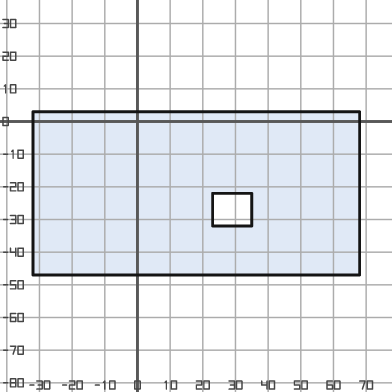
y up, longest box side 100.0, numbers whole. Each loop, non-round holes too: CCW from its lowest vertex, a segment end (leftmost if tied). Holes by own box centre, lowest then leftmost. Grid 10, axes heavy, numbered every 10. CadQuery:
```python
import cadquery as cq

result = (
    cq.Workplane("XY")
    .moveTo(-32.0, -47.0)
    .lineTo(68.0, -47.0)
    .lineTo(68.0, 3.0)
    .lineTo(-32.0, 3.0)
    .close()
    .moveTo(23.0, -32.0)
    .lineTo(35.0, -32.0)
    .lineTo(35.0, -22.0)
    .lineTo(23.0, -22.0)
    .close()
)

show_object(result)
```